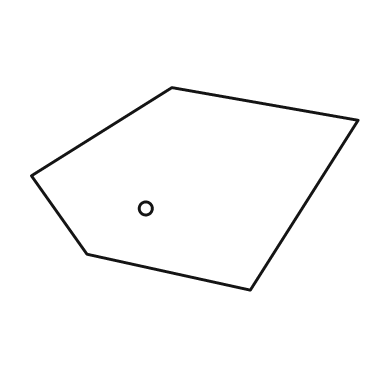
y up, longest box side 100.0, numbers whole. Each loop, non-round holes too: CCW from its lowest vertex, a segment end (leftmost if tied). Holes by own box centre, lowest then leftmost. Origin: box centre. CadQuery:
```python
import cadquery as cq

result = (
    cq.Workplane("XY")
    .moveTo(17.0, -31.0)
    .lineTo(50.0, 21.0)
    .lineTo(-7.0, 31.0)
    .lineTo(-50.0, 4.0)
    .lineTo(-33.0, -20.0)
    .close()
    .moveTo(-15.0, -6.0)
    .circle(2.0)
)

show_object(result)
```